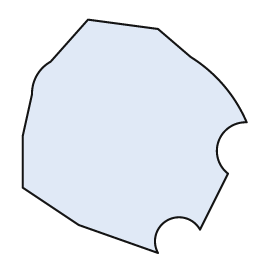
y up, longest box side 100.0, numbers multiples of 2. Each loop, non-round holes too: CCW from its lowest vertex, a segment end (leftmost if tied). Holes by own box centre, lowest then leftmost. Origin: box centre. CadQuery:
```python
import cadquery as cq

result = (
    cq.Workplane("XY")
    .moveTo(10.0, -50.0)
    .threePointArc((14.0, -36.0), (28.0, -40.0))
    .lineTo(40.0, -16.0)
    .threePointArc((36.0, -2.0), (48.0, 6.0))
    .threePointArc((38.0, 22.0), (24.0, 34.0))
    .lineTo(10.0, 46.0)
    .lineTo(-20.0, 50.0)
    .lineTo(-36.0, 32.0)
    .threePointArc((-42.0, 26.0), (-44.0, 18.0))
    .lineTo(-48.0, 0.0)
    .lineTo(-48.0, -22.0)
    .lineTo(-24.0, -38.0)
    .close()
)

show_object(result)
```